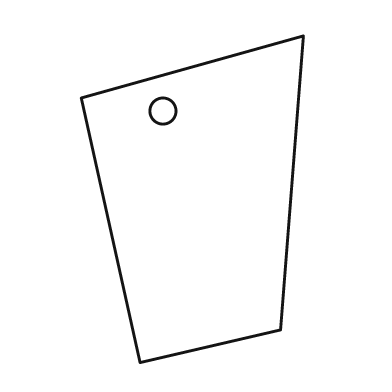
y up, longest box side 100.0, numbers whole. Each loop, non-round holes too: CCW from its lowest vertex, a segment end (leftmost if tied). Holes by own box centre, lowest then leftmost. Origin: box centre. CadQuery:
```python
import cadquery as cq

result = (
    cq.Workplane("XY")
    .moveTo(-16.0, -50.0)
    .lineTo(27.0, -40.0)
    .lineTo(34.0, 50.0)
    .lineTo(-34.0, 31.0)
    .close()
    .moveTo(-9.0, 27.0)
    .circle(4.0)
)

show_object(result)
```